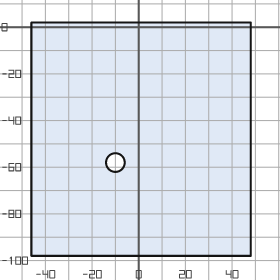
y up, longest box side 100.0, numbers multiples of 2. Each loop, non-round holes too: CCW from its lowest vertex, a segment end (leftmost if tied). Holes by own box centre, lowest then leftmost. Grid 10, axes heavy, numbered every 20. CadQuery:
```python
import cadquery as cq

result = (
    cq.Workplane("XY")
    .moveTo(-46.0, -98.0)
    .lineTo(48.0, -98.0)
    .lineTo(48.0, 2.0)
    .lineTo(-46.0, 2.0)
    .close()
    .moveTo(-10.0, -58.0)
    .circle(4.0)
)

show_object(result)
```